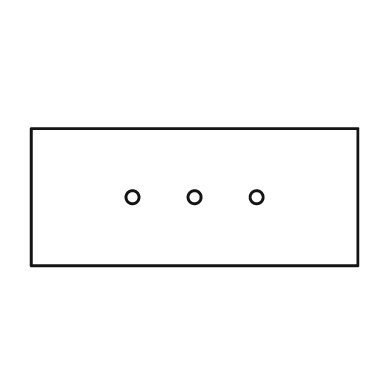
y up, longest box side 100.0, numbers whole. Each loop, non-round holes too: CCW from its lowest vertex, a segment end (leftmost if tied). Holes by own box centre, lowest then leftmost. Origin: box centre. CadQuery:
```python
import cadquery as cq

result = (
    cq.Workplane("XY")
    .moveTo(-50.0, -21.0)
    .lineTo(50.0, -21.0)
    .lineTo(50.0, 21.0)
    .lineTo(-50.0, 21.0)
    .close()
    .moveTo(-19.0, 0.0)
    .circle(2.0)
    .moveTo(0.0, 0.0)
    .circle(2.0)
    .moveTo(19.0, 0.0)
    .circle(2.0)
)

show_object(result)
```